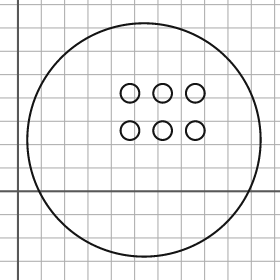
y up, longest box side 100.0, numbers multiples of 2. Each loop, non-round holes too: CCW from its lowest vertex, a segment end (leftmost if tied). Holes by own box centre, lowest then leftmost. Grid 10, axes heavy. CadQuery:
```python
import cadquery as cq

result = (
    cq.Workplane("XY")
    .moveTo(54.0, 22.0)
    .circle(50.0)
    .moveTo(48.0, 26.0)
    .circle(4.0)
    .moveTo(62.0, 26.0)
    .circle(4.0)
    .moveTo(76.0, 26.0)
    .circle(4.0)
    .moveTo(48.0, 42.0)
    .circle(4.0)
    .moveTo(62.0, 42.0)
    .circle(4.0)
    .moveTo(76.0, 42.0)
    .circle(4.0)
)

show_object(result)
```